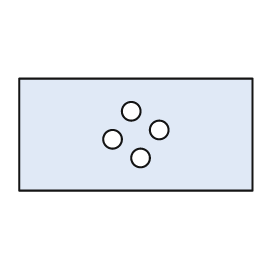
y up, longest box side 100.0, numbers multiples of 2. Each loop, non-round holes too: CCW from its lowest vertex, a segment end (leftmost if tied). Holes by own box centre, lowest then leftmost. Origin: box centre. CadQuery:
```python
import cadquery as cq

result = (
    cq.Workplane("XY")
    .moveTo(-50.0, -24.0)
    .lineTo(50.0, -24.0)
    .lineTo(50.0, 24.0)
    .lineTo(-50.0, 24.0)
    .close()
    .moveTo(2.0, -10.0)
    .circle(4.0)
    .moveTo(-10.0, -2.0)
    .circle(4.0)
    .moveTo(10.0, 2.0)
    .circle(4.0)
    .moveTo(-2.0, 10.0)
    .circle(4.0)
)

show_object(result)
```